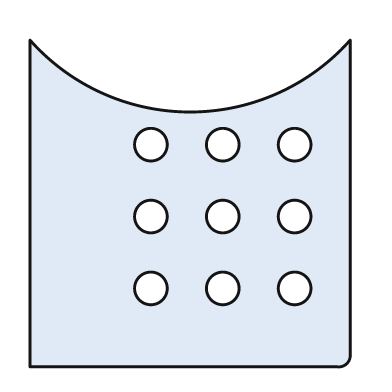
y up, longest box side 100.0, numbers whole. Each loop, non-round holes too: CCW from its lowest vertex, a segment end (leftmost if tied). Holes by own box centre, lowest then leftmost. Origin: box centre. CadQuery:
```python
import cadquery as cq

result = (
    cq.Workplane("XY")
    .moveTo(-49.0, -50.0)
    .lineTo(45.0, -50.0)
    .threePointArc((48.0, -49.0), (49.0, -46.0))
    .lineTo(49.0, 50.0)
    .threePointArc((0.0, 28.0), (-49.0, 50.0))
    .close()
    .moveTo(-12.0, -26.0)
    .circle(5.0)
    .moveTo(10.0, -26.0)
    .circle(5.0)
    .moveTo(32.0, -26.0)
    .circle(5.0)
    .moveTo(-12.0, -4.0)
    .circle(5.0)
    .moveTo(10.0, -4.0)
    .circle(5.0)
    .moveTo(32.0, -4.0)
    .circle(5.0)
    .moveTo(-12.0, 18.0)
    .circle(5.0)
    .moveTo(10.0, 18.0)
    .circle(5.0)
    .moveTo(32.0, 18.0)
    .circle(5.0)
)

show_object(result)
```